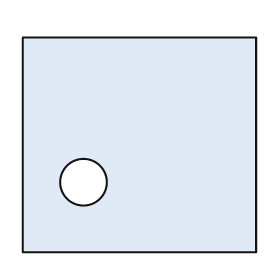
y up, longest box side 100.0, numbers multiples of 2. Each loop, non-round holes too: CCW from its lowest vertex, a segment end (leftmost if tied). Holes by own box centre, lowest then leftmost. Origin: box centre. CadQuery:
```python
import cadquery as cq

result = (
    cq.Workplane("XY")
    .moveTo(-50.0, -46.0)
    .lineTo(50.0, -46.0)
    .lineTo(50.0, 46.0)
    .lineTo(-50.0, 46.0)
    .close()
    .moveTo(-24.0, -16.0)
    .circle(10.0)
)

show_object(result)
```